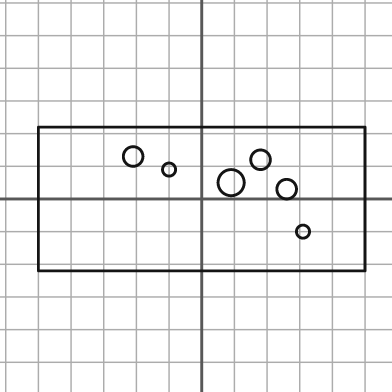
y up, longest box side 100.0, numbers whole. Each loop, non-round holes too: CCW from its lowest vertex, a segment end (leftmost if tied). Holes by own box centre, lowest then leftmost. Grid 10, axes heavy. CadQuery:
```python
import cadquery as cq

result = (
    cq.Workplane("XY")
    .moveTo(-50.0, -22.0)
    .lineTo(50.0, -22.0)
    .lineTo(50.0, 22.0)
    .lineTo(-50.0, 22.0)
    .close()
    .moveTo(31.0, -10.0)
    .circle(2.0)
    .moveTo(26.0, 3.0)
    .circle(3.0)
    .moveTo(9.0, 5.0)
    .circle(4.0)
    .moveTo(-10.0, 9.0)
    .circle(2.0)
    .moveTo(18.0, 12.0)
    .circle(3.0)
    .moveTo(-21.0, 13.0)
    .circle(3.0)
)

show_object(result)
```